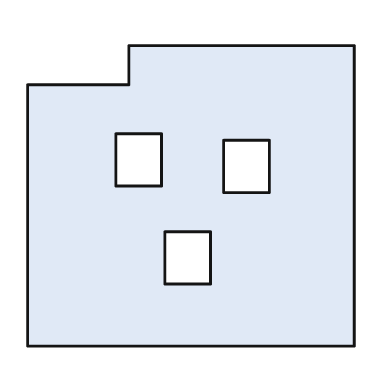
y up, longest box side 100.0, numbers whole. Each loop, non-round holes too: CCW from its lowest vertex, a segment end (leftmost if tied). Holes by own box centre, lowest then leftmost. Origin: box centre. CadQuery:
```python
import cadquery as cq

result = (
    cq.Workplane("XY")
    .moveTo(-50.0, -46.0)
    .lineTo(50.0, -46.0)
    .lineTo(50.0, 46.0)
    .lineTo(-19.0, 46.0)
    .lineTo(-19.0, 34.0)
    .lineTo(-50.0, 34.0)
    .close()
    .moveTo(-8.0, -27.0)
    .lineTo(6.0, -27.0)
    .lineTo(6.0, -11.0)
    .lineTo(-8.0, -11.0)
    .close()
    .moveTo(10.0, 1.0)
    .lineTo(24.0, 1.0)
    .lineTo(24.0, 17.0)
    .lineTo(10.0, 17.0)
    .close()
    .moveTo(-23.0, 3.0)
    .lineTo(-9.0, 3.0)
    .lineTo(-9.0, 19.0)
    .lineTo(-23.0, 19.0)
    .close()
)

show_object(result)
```